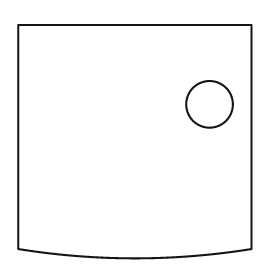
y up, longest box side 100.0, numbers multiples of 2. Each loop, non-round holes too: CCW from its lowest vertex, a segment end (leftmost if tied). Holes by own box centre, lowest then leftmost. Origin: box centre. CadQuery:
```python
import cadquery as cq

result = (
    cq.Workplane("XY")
    .moveTo(-50.0, -46.0)
    .threePointArc((0.0, -50.0), (50.0, -46.0))
    .lineTo(50.0, 50.0)
    .lineTo(-50.0, 50.0)
    .close()
    .moveTo(32.0, 16.0)
    .circle(10.0)
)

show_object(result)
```